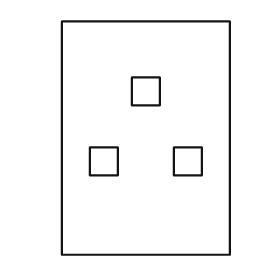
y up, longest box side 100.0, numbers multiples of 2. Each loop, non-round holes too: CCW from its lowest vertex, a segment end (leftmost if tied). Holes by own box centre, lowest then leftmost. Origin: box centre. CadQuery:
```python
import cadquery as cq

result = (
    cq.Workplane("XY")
    .moveTo(-36.0, -50.0)
    .lineTo(36.0, -50.0)
    .lineTo(36.0, 50.0)
    .lineTo(-36.0, 50.0)
    .close()
    .moveTo(-24.0, -16.0)
    .lineTo(-12.0, -16.0)
    .lineTo(-12.0, -4.0)
    .lineTo(-24.0, -4.0)
    .close()
    .moveTo(12.0, -16.0)
    .lineTo(24.0, -16.0)
    .lineTo(24.0, -4.0)
    .lineTo(12.0, -4.0)
    .close()
    .moveTo(-6.0, 14.0)
    .lineTo(6.0, 14.0)
    .lineTo(6.0, 26.0)
    .lineTo(-6.0, 26.0)
    .close()
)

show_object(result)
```